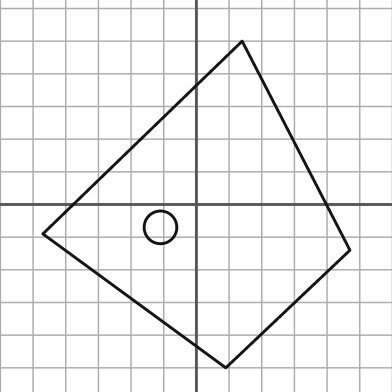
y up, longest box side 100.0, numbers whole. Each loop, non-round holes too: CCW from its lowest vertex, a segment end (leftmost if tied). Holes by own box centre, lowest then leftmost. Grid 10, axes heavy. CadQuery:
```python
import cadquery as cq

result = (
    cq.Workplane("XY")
    .moveTo(9.0, -50.0)
    .lineTo(47.0, -14.0)
    .lineTo(14.0, 50.0)
    .lineTo(-47.0, -9.0)
    .close()
    .moveTo(-11.0, -7.0)
    .circle(5.0)
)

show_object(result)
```